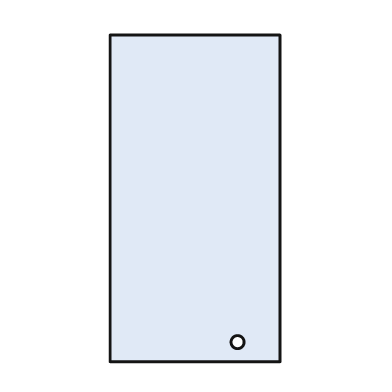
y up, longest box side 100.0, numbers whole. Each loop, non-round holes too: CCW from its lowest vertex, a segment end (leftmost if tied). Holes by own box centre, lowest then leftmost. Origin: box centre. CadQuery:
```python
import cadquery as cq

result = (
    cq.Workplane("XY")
    .moveTo(-26.0, -50.0)
    .lineTo(26.0, -50.0)
    .lineTo(26.0, 50.0)
    .lineTo(-26.0, 50.0)
    .close()
    .moveTo(13.0, -44.0)
    .circle(2.0)
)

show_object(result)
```